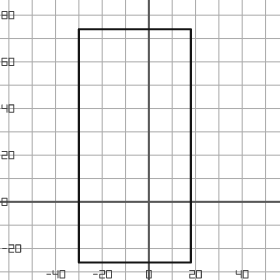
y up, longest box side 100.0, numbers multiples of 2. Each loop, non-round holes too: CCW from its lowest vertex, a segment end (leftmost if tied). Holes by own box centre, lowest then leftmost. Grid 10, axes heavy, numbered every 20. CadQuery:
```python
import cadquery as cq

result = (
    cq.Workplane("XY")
    .moveTo(-30.0, -26.0)
    .lineTo(18.0, -26.0)
    .lineTo(18.0, 74.0)
    .lineTo(-30.0, 74.0)
    .close()
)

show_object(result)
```